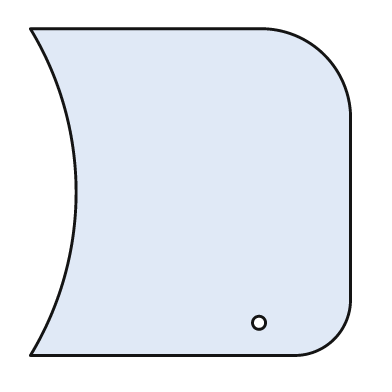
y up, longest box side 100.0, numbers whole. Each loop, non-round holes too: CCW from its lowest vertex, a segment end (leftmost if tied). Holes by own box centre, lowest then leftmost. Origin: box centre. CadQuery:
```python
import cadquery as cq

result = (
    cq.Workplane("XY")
    .moveTo(-49.0, -50.0)
    .lineTo(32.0, -50.0)
    .threePointArc((44.0, -45.0), (49.0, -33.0))
    .lineTo(49.0, 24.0)
    .threePointArc((41.0, 42.0), (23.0, 50.0))
    .lineTo(-49.0, 50.0)
    .threePointArc((-35.0, 0.0), (-49.0, -50.0))
    .close()
    .moveTo(21.0, -40.0)
    .circle(2.0)
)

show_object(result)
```